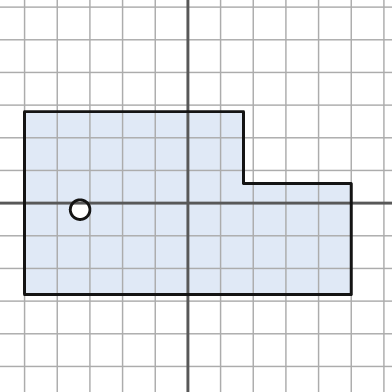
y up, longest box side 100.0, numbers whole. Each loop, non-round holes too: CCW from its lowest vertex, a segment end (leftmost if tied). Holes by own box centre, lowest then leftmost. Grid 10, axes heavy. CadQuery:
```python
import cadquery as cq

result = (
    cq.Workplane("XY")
    .moveTo(-50.0, -28.0)
    .lineTo(50.0, -28.0)
    .lineTo(50.0, 6.0)
    .lineTo(17.0, 6.0)
    .lineTo(17.0, 28.0)
    .lineTo(-50.0, 28.0)
    .close()
    .moveTo(-33.0, -2.0)
    .circle(3.0)
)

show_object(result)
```